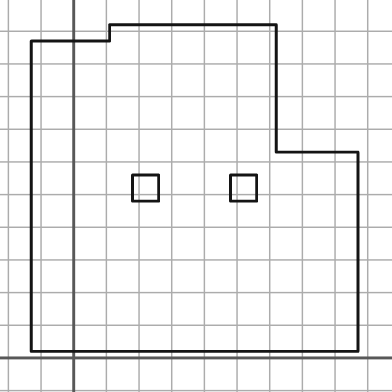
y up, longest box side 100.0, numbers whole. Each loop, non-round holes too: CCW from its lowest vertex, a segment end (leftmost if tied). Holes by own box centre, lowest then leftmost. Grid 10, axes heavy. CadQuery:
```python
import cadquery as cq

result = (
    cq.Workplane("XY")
    .moveTo(-13.0, 2.0)
    .lineTo(87.0, 2.0)
    .lineTo(87.0, 63.0)
    .lineTo(62.0, 63.0)
    .lineTo(62.0, 102.0)
    .lineTo(11.0, 102.0)
    .lineTo(11.0, 97.0)
    .lineTo(-13.0, 97.0)
    .close()
    .moveTo(18.0, 48.0)
    .lineTo(26.0, 48.0)
    .lineTo(26.0, 56.0)
    .lineTo(18.0, 56.0)
    .close()
    .moveTo(48.0, 48.0)
    .lineTo(56.0, 48.0)
    .lineTo(56.0, 56.0)
    .lineTo(48.0, 56.0)
    .close()
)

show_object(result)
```